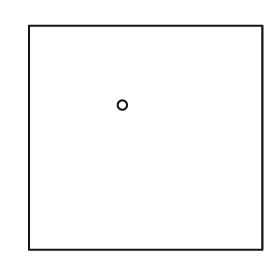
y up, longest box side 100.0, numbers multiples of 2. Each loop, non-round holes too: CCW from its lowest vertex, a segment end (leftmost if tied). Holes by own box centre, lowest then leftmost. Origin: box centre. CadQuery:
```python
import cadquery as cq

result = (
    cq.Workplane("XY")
    .moveTo(-50.0, -48.0)
    .lineTo(50.0, -48.0)
    .lineTo(50.0, 48.0)
    .lineTo(-50.0, 48.0)
    .close()
    .moveTo(-10.0, 14.0)
    .circle(2.0)
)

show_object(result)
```